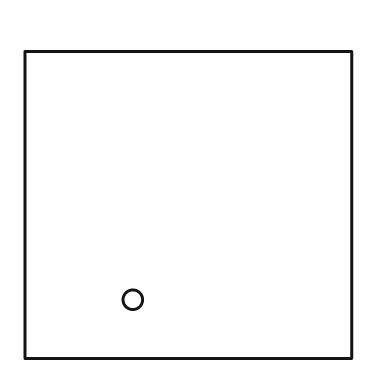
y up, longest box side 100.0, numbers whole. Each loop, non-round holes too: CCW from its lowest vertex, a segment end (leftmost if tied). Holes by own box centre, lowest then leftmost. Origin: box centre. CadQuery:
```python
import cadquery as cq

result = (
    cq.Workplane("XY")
    .moveTo(-50.0, -47.0)
    .lineTo(50.0, -47.0)
    .lineTo(50.0, 47.0)
    .lineTo(-50.0, 47.0)
    .close()
    .moveTo(-17.0, -29.0)
    .circle(3.0)
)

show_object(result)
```